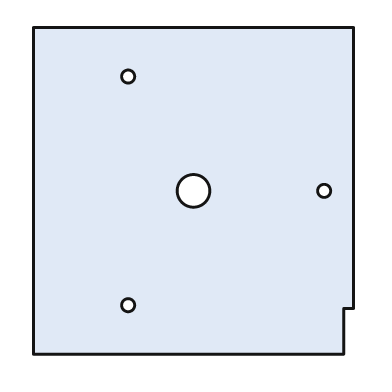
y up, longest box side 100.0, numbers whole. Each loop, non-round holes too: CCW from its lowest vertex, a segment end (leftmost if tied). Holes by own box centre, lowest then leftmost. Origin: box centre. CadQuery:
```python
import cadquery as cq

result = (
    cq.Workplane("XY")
    .moveTo(-49.0, -50.0)
    .lineTo(46.0, -50.0)
    .lineTo(46.0, -36.0)
    .lineTo(49.0, -36.0)
    .lineTo(49.0, 50.0)
    .lineTo(-49.0, 50.0)
    .close()
    .moveTo(-20.0, -35.0)
    .circle(2.0)
    .moveTo(0.0, 0.0)
    .circle(5.0)
    .moveTo(40.0, 0.0)
    .circle(2.0)
    .moveTo(-20.0, 35.0)
    .circle(2.0)
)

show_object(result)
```